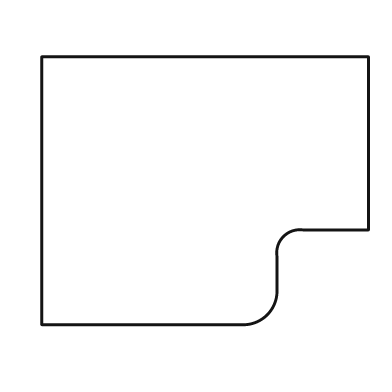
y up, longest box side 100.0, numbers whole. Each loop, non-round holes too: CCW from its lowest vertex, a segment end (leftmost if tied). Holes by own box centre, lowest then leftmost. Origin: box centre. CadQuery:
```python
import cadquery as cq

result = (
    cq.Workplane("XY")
    .moveTo(-50.0, -41.0)
    .lineTo(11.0, -41.0)
    .threePointArc((19.0, -38.0), (22.0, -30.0))
    .lineTo(22.0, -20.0)
    .threePointArc((24.0, -14.0), (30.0, -12.0))
    .lineTo(50.0, -12.0)
    .lineTo(50.0, 41.0)
    .lineTo(-50.0, 41.0)
    .close()
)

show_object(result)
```